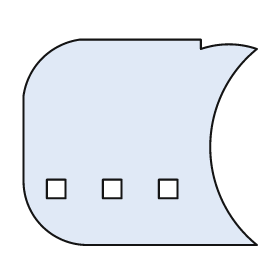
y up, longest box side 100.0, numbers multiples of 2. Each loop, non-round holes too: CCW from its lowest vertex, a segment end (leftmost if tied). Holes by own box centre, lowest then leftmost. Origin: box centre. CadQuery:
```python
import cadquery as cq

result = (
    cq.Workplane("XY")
    .moveTo(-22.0, -44.0)
    .lineTo(50.0, -44.0)
    .threePointArc((30.0, -2.0), (50.0, 40.0))
    .threePointArc((38.0, 42.0), (26.0, 40.0))
    .lineTo(26.0, 44.0)
    .lineTo(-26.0, 44.0)
    .threePointArc((-42.0, 36.0), (-50.0, 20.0))
    .lineTo(-50.0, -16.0)
    .threePointArc((-42.0, -36.0), (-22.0, -44.0))
    .close()
    .moveTo(-40.0, -24.0)
    .lineTo(-32.0, -24.0)
    .lineTo(-32.0, -16.0)
    .lineTo(-40.0, -16.0)
    .close()
    .moveTo(-16.0, -24.0)
    .lineTo(-8.0, -24.0)
    .lineTo(-8.0, -16.0)
    .lineTo(-16.0, -16.0)
    .close()
    .moveTo(8.0, -24.0)
    .lineTo(16.0, -24.0)
    .lineTo(16.0, -16.0)
    .lineTo(8.0, -16.0)
    .close()
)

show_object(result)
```